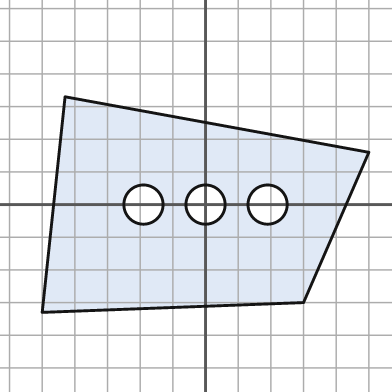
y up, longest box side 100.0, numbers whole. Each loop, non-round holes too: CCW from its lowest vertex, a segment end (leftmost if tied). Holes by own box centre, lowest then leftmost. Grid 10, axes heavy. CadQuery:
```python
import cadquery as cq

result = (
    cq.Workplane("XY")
    .moveTo(-50.0, -33.0)
    .lineTo(30.0, -30.0)
    .lineTo(50.0, 16.0)
    .lineTo(-43.0, 33.0)
    .close()
    .moveTo(-19.0, 0.0)
    .circle(6.0)
    .moveTo(0.0, 0.0)
    .circle(6.0)
    .moveTo(19.0, 0.0)
    .circle(6.0)
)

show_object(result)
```